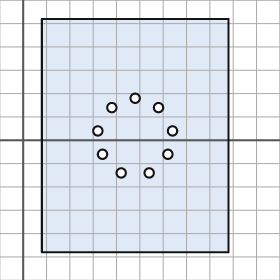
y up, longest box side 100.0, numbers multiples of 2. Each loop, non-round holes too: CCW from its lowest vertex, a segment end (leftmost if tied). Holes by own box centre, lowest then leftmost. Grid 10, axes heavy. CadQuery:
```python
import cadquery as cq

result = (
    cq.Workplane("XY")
    .moveTo(8.0, -48.0)
    .lineTo(88.0, -48.0)
    .lineTo(88.0, 52.0)
    .lineTo(8.0, 52.0)
    .close()
    .moveTo(42.0, -14.0)
    .circle(2.0)
    .moveTo(54.0, -14.0)
    .circle(2.0)
    .moveTo(34.0, -6.0)
    .circle(2.0)
    .moveTo(62.0, -6.0)
    .circle(2.0)
    .moveTo(32.0, 4.0)
    .circle(2.0)
    .moveTo(64.0, 4.0)
    .circle(2.0)
    .moveTo(38.0, 14.0)
    .circle(2.0)
    .moveTo(58.0, 14.0)
    .circle(2.0)
    .moveTo(48.0, 18.0)
    .circle(2.0)
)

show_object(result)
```